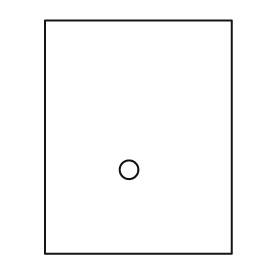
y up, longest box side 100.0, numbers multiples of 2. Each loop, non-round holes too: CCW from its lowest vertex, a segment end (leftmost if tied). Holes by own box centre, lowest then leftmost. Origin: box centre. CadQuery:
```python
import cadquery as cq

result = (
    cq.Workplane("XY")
    .moveTo(-40.0, -50.0)
    .lineTo(40.0, -50.0)
    .lineTo(40.0, 50.0)
    .lineTo(-40.0, 50.0)
    .close()
    .moveTo(-4.0, -14.0)
    .circle(4.0)
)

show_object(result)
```